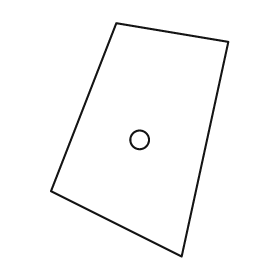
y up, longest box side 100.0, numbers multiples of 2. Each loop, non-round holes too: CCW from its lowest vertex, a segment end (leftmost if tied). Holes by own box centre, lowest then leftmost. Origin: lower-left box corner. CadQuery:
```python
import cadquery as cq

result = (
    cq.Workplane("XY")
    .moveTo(56.0, 0.0)
    .lineTo(76.0, 92.0)
    .lineTo(28.0, 100.0)
    .lineTo(0.0, 28.0)
    .close()
    .moveTo(38.0, 50.0)
    .circle(4.0)
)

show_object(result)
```